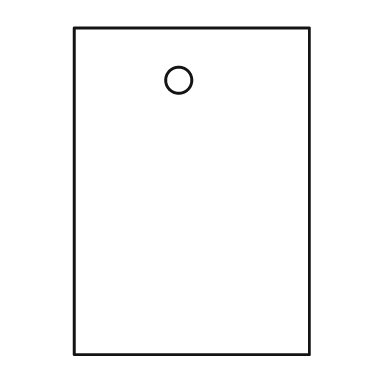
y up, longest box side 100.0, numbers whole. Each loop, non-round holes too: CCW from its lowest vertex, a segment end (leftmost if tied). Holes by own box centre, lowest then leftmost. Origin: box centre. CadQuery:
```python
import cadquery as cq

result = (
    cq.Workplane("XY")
    .moveTo(-36.0, -50.0)
    .lineTo(36.0, -50.0)
    .lineTo(36.0, 50.0)
    .lineTo(-36.0, 50.0)
    .close()
    .moveTo(-4.0, 34.0)
    .circle(4.0)
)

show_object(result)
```